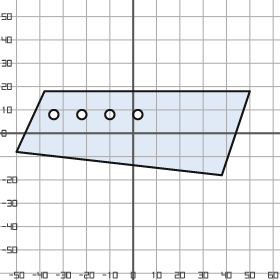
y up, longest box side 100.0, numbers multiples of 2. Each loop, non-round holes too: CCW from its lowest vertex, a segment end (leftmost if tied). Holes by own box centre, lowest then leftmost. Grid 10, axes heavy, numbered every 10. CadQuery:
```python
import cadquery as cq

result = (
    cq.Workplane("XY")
    .moveTo(38.0, -18.0)
    .lineTo(50.0, 18.0)
    .lineTo(-38.0, 18.0)
    .lineTo(-50.0, -8.0)
    .close()
    .moveTo(-34.0, 8.0)
    .circle(2.0)
    .moveTo(-22.0, 8.0)
    .circle(2.0)
    .moveTo(-10.0, 8.0)
    .circle(2.0)
    .moveTo(2.0, 8.0)
    .circle(2.0)
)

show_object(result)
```